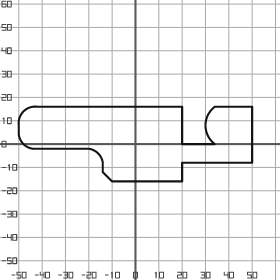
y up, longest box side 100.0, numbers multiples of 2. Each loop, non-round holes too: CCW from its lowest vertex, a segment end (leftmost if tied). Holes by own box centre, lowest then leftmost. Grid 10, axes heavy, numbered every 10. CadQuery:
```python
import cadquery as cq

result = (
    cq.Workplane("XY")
    .moveTo(-10.0, -16.0)
    .lineTo(20.0, -16.0)
    .lineTo(20.0, -8.0)
    .lineTo(50.0, -8.0)
    .lineTo(50.0, 16.0)
    .lineTo(34.0, 16.0)
    .threePointArc((30.0, 8.0), (34.0, 0.0))
    .lineTo(20.0, 0.0)
    .lineTo(20.0, 16.0)
    .lineTo(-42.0, 16.0)
    .threePointArc((-48.0, 14.0), (-50.0, 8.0))
    .lineTo(-50.0, 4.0)
    .threePointArc((-48.0, 0.0), (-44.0, -2.0))
    .lineTo(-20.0, -2.0)
    .threePointArc((-16.0, -4.0), (-14.0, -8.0))
    .lineTo(-14.0, -12.0)
    .close()
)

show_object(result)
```